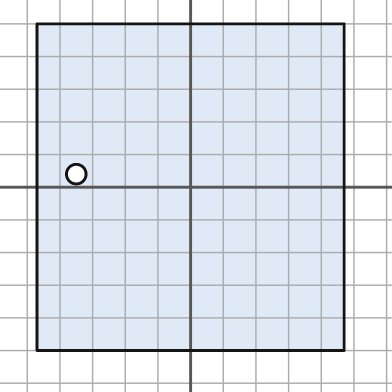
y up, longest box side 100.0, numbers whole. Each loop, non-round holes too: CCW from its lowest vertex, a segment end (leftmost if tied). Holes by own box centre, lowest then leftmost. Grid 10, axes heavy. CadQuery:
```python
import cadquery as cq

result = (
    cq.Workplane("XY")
    .moveTo(-47.0, -50.0)
    .lineTo(47.0, -50.0)
    .lineTo(47.0, 50.0)
    .lineTo(-47.0, 50.0)
    .close()
    .moveTo(-35.0, 4.0)
    .circle(3.0)
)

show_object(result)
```